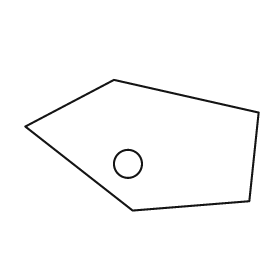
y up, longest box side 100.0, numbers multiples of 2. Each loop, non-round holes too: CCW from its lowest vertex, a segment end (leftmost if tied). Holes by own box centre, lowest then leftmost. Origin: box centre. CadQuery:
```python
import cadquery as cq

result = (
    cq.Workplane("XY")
    .moveTo(-4.0, -28.0)
    .lineTo(46.0, -24.0)
    .lineTo(50.0, 14.0)
    .lineTo(-12.0, 28.0)
    .lineTo(-50.0, 8.0)
    .close()
    .moveTo(-6.0, -8.0)
    .circle(6.0)
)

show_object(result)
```